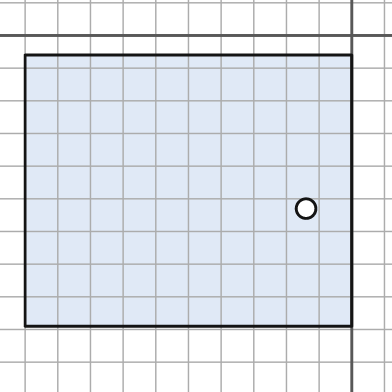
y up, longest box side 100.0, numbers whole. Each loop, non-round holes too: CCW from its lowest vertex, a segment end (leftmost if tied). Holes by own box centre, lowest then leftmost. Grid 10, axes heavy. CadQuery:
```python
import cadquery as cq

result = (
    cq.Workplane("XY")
    .moveTo(-100.0, -89.0)
    .lineTo(0.0, -89.0)
    .lineTo(0.0, -6.0)
    .lineTo(-100.0, -6.0)
    .close()
    .moveTo(-14.0, -53.0)
    .circle(3.0)
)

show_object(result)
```